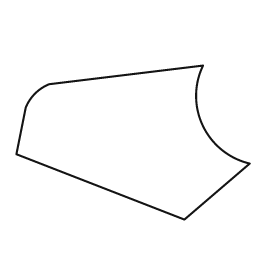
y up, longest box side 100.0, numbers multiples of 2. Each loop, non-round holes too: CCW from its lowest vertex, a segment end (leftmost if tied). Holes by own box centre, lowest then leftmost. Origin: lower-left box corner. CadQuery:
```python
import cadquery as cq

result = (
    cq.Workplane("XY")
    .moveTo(72.0, 0.0)
    .lineTo(100.0, 24.0)
    .threePointArc((80.0, 40.0), (80.0, 66.0))
    .lineTo(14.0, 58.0)
    .threePointArc((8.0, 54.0), (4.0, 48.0))
    .lineTo(0.0, 28.0)
    .close()
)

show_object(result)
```